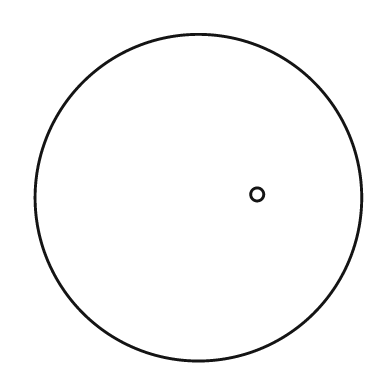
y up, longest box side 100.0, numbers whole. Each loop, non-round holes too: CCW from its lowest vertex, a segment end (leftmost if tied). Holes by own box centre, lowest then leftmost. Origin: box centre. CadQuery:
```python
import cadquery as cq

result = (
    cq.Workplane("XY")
    .moveTo(0.0, 0.0)
    .circle(50.0)
    .moveTo(18.0, 1.0)
    .circle(2.0)
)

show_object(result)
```